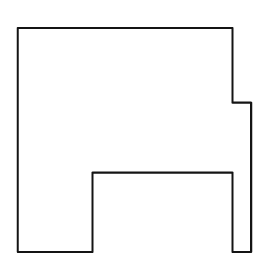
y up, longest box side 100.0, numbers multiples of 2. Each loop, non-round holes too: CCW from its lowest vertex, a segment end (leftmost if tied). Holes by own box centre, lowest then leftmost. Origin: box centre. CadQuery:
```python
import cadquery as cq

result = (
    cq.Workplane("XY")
    .moveTo(-50.0, -48.0)
    .lineTo(-18.0, -48.0)
    .lineTo(-18.0, -14.0)
    .lineTo(42.0, -14.0)
    .lineTo(42.0, -48.0)
    .lineTo(50.0, -48.0)
    .lineTo(50.0, 16.0)
    .lineTo(42.0, 16.0)
    .lineTo(42.0, 48.0)
    .lineTo(-50.0, 48.0)
    .close()
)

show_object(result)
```